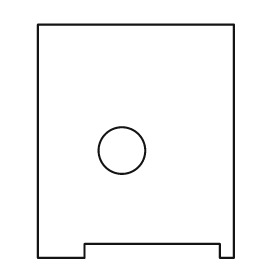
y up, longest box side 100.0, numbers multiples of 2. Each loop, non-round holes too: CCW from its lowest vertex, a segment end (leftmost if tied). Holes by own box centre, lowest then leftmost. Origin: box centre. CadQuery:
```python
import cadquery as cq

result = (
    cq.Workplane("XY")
    .moveTo(-42.0, -50.0)
    .lineTo(-22.0, -50.0)
    .lineTo(-22.0, -44.0)
    .lineTo(36.0, -44.0)
    .lineTo(36.0, -50.0)
    .lineTo(42.0, -50.0)
    .lineTo(42.0, 50.0)
    .lineTo(-42.0, 50.0)
    .close()
    .moveTo(-6.0, -4.0)
    .circle(10.0)
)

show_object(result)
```